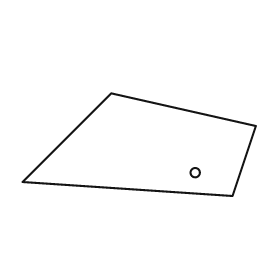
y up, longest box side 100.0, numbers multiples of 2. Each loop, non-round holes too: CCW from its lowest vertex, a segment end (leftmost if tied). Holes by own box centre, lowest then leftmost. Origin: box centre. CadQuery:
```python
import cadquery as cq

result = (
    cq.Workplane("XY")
    .moveTo(40.0, -22.0)
    .lineTo(50.0, 8.0)
    .lineTo(-12.0, 22.0)
    .lineTo(-50.0, -16.0)
    .close()
    .moveTo(24.0, -12.0)
    .circle(2.0)
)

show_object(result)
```